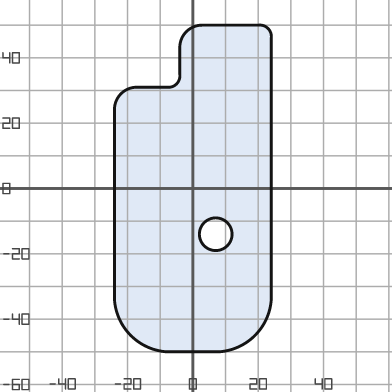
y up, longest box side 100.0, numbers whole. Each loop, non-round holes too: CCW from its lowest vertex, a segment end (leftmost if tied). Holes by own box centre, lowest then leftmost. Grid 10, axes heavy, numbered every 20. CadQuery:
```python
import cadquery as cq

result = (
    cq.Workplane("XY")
    .moveTo(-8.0, -50.0)
    .lineTo(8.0, -50.0)
    .threePointArc((19.0, -45.0), (24.0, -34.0))
    .lineTo(24.0, 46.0)
    .threePointArc((23.0, 49.0), (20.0, 50.0))
    .lineTo(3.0, 50.0)
    .threePointArc((-2.0, 48.0), (-4.0, 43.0))
    .lineTo(-4.0, 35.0)
    .threePointArc((-5.0, 32.0), (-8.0, 31.0))
    .lineTo(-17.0, 31.0)
    .threePointArc((-22.0, 29.0), (-24.0, 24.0))
    .lineTo(-24.0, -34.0)
    .threePointArc((-19.0, -45.0), (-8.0, -50.0))
    .close()
    .moveTo(7.0, -14.0)
    .circle(5.0)
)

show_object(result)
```